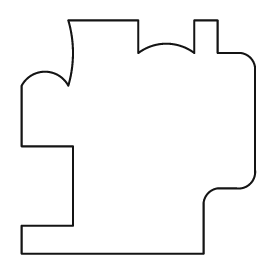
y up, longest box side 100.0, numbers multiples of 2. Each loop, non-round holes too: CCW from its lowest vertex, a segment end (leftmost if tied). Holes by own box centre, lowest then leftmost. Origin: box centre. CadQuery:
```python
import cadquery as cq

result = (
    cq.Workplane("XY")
    .moveTo(-50.0, -50.0)
    .lineTo(28.0, -50.0)
    .lineTo(28.0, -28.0)
    .threePointArc((30.0, -24.0), (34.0, -22.0))
    .lineTo(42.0, -22.0)
    .threePointArc((48.0, -20.0), (50.0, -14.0))
    .lineTo(50.0, 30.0)
    .threePointArc((48.0, 34.0), (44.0, 36.0))
    .lineTo(34.0, 36.0)
    .lineTo(34.0, 50.0)
    .lineTo(24.0, 50.0)
    .lineTo(24.0, 36.0)
    .threePointArc((12.0, 40.0), (0.0, 36.0))
    .lineTo(0.0, 50.0)
    .lineTo(-30.0, 50.0)
    .threePointArc((-28.0, 36.0), (-30.0, 22.0))
    .threePointArc((-40.0, 28.0), (-50.0, 22.0))
    .lineTo(-50.0, -4.0)
    .lineTo(-28.0, -4.0)
    .lineTo(-28.0, -38.0)
    .lineTo(-50.0, -38.0)
    .close()
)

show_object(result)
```